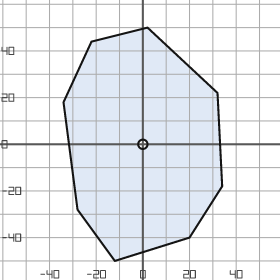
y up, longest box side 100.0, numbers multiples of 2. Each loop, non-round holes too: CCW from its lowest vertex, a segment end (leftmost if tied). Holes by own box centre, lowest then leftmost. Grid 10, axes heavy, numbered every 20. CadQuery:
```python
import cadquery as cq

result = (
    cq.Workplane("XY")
    .moveTo(-12.0, -50.0)
    .lineTo(20.0, -40.0)
    .lineTo(34.0, -18.0)
    .lineTo(32.0, 22.0)
    .lineTo(2.0, 50.0)
    .lineTo(-22.0, 44.0)
    .lineTo(-34.0, 18.0)
    .lineTo(-28.0, -28.0)
    .close()
    .moveTo(0.0, 0.0)
    .circle(2.0)
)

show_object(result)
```